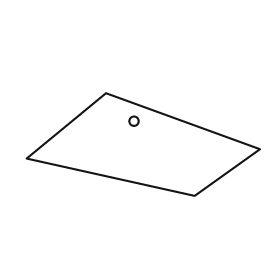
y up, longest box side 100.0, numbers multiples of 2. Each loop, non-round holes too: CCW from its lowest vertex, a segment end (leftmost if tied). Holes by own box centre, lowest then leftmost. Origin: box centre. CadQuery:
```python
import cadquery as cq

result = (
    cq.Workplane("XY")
    .moveTo(22.0, -22.0)
    .lineTo(50.0, -2.0)
    .lineTo(-16.0, 22.0)
    .lineTo(-50.0, -6.0)
    .close()
    .moveTo(-4.0, 10.0)
    .circle(2.0)
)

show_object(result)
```